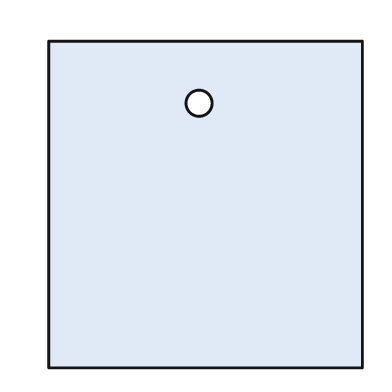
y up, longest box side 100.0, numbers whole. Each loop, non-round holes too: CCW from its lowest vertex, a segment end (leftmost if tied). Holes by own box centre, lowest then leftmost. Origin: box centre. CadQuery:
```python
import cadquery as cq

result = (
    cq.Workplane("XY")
    .moveTo(-48.0, -50.0)
    .lineTo(48.0, -50.0)
    .lineTo(48.0, 50.0)
    .lineTo(-48.0, 50.0)
    .close()
    .moveTo(-2.0, 31.0)
    .circle(4.0)
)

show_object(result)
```